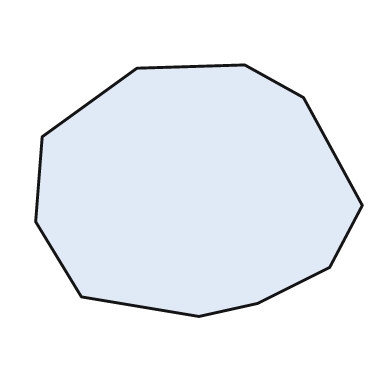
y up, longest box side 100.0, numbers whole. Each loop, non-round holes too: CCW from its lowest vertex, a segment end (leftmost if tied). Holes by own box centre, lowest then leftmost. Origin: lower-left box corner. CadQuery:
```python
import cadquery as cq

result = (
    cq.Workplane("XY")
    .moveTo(50.0, 0.0)
    .lineTo(68.0, 4.0)
    .lineTo(90.0, 15.0)
    .lineTo(100.0, 34.0)
    .lineTo(82.0, 67.0)
    .lineTo(64.0, 77.0)
    .lineTo(31.0, 76.0)
    .lineTo(2.0, 55.0)
    .lineTo(0.0, 29.0)
    .lineTo(14.0, 6.0)
    .close()
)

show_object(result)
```